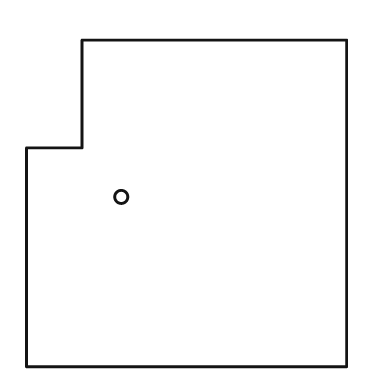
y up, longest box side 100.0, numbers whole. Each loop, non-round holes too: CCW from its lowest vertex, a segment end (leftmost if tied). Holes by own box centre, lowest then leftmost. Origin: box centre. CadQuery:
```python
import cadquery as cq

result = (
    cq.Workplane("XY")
    .moveTo(-49.0, -50.0)
    .lineTo(49.0, -50.0)
    .lineTo(49.0, 50.0)
    .lineTo(-32.0, 50.0)
    .lineTo(-32.0, 17.0)
    .lineTo(-49.0, 17.0)
    .close()
    .moveTo(-20.0, 2.0)
    .circle(2.0)
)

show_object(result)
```